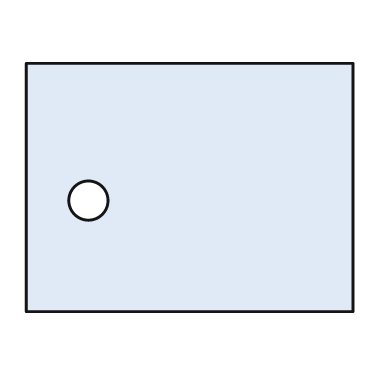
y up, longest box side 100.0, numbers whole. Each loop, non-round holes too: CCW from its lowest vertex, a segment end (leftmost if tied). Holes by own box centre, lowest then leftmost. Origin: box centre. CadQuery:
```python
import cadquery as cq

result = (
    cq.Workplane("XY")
    .moveTo(-50.0, -38.0)
    .lineTo(50.0, -38.0)
    .lineTo(50.0, 38.0)
    .lineTo(-50.0, 38.0)
    .close()
    .moveTo(-31.0, -4.0)
    .circle(6.0)
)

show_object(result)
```